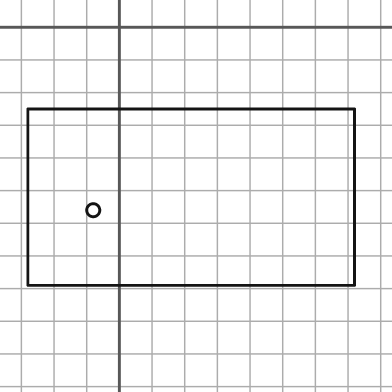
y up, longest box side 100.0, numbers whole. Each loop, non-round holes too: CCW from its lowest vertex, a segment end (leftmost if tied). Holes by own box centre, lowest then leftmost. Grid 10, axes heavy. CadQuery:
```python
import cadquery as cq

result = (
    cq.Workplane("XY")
    .moveTo(-28.0, -79.0)
    .lineTo(72.0, -79.0)
    .lineTo(72.0, -25.0)
    .lineTo(-28.0, -25.0)
    .close()
    .moveTo(-8.0, -56.0)
    .circle(2.0)
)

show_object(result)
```